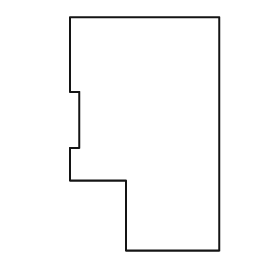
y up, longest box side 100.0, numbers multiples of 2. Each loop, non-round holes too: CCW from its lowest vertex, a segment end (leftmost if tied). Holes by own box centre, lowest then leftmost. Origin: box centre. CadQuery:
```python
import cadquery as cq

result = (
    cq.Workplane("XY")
    .moveTo(-8.0, -50.0)
    .lineTo(32.0, -50.0)
    .lineTo(32.0, 50.0)
    .lineTo(-32.0, 50.0)
    .lineTo(-32.0, 18.0)
    .lineTo(-28.0, 18.0)
    .lineTo(-28.0, -6.0)
    .lineTo(-32.0, -6.0)
    .lineTo(-32.0, -20.0)
    .lineTo(-8.0, -20.0)
    .close()
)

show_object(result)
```